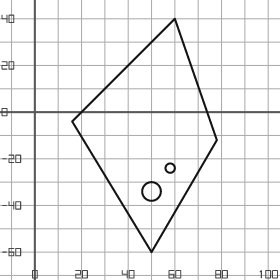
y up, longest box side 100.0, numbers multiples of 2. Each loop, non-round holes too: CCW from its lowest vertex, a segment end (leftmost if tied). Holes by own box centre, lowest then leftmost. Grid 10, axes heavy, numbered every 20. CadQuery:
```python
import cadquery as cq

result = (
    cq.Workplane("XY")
    .moveTo(50.0, -60.0)
    .lineTo(78.0, -12.0)
    .lineTo(60.0, 40.0)
    .lineTo(16.0, -4.0)
    .close()
    .moveTo(50.0, -34.0)
    .circle(4.0)
    .moveTo(58.0, -24.0)
    .circle(2.0)
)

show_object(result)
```